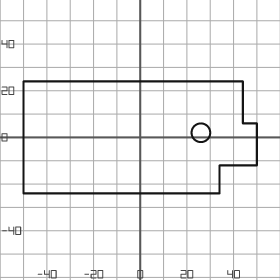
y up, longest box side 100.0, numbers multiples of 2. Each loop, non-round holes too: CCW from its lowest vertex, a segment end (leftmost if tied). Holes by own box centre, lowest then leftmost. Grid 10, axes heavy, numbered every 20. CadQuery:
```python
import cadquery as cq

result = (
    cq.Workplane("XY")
    .moveTo(-50.0, -24.0)
    .lineTo(34.0, -24.0)
    .lineTo(34.0, -12.0)
    .lineTo(50.0, -12.0)
    .lineTo(50.0, 6.0)
    .lineTo(44.0, 6.0)
    .lineTo(44.0, 24.0)
    .lineTo(-50.0, 24.0)
    .close()
    .moveTo(26.0, 2.0)
    .circle(4.0)
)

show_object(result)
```